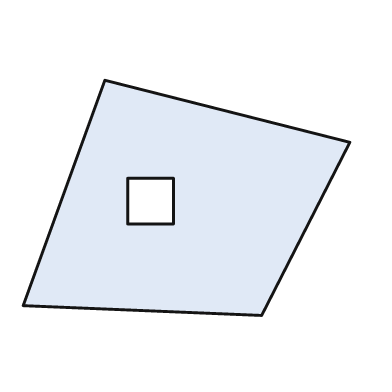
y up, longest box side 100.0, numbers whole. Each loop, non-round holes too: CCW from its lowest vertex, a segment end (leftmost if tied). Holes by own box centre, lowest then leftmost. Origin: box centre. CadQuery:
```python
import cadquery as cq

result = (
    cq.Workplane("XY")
    .moveTo(23.0, -36.0)
    .lineTo(50.0, 17.0)
    .lineTo(-25.0, 36.0)
    .lineTo(-50.0, -33.0)
    .close()
    .moveTo(-18.0, -8.0)
    .lineTo(-4.0, -8.0)
    .lineTo(-4.0, 6.0)
    .lineTo(-18.0, 6.0)
    .close()
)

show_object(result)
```